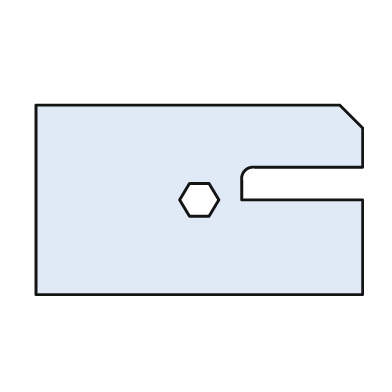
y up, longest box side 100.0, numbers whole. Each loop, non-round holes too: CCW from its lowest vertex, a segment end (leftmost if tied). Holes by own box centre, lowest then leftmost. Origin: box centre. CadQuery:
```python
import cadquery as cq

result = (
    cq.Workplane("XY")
    .moveTo(-50.0, -29.0)
    .lineTo(50.0, -29.0)
    .lineTo(50.0, 0.0)
    .lineTo(13.0, 0.0)
    .lineTo(13.0, 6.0)
    .threePointArc((14.0, 9.0), (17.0, 10.0))
    .lineTo(50.0, 10.0)
    .lineTo(50.0, 22.0)
    .lineTo(43.0, 29.0)
    .lineTo(-50.0, 29.0)
    .close()
    .moveTo(-3.0, -5.0)
    .lineTo(3.0, -5.0)
    .lineTo(6.0, 0.0)
    .lineTo(3.0, 5.0)
    .lineTo(-3.0, 5.0)
    .lineTo(-6.0, 0.0)
    .close()
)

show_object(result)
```